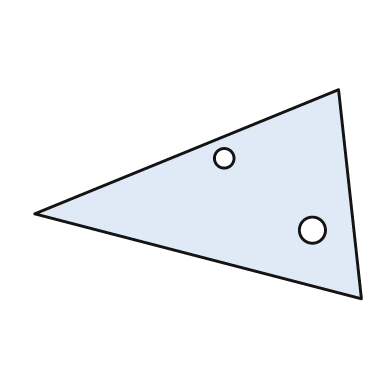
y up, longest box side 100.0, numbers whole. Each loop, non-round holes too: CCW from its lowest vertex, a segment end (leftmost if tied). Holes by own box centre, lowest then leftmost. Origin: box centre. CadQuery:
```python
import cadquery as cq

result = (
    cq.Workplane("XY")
    .moveTo(50.0, -32.0)
    .lineTo(43.0, 32.0)
    .lineTo(-50.0, -6.0)
    .close()
    .moveTo(35.0, -11.0)
    .circle(4.0)
    .moveTo(8.0, 11.0)
    .circle(3.0)
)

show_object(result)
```